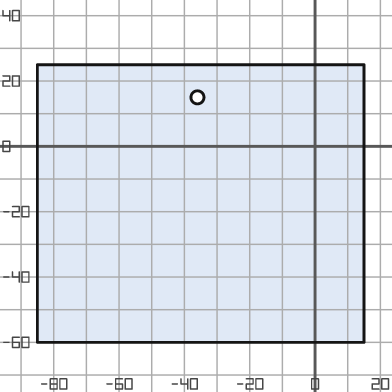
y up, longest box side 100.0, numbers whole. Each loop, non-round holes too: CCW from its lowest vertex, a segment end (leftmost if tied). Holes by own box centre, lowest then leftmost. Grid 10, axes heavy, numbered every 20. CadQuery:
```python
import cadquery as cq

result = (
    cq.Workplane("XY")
    .moveTo(-85.0, -60.0)
    .lineTo(15.0, -60.0)
    .lineTo(15.0, 25.0)
    .lineTo(-85.0, 25.0)
    .close()
    .moveTo(-36.0, 15.0)
    .circle(2.0)
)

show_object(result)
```